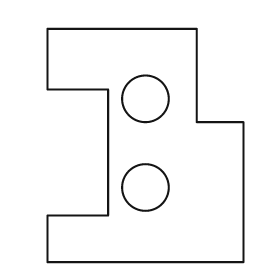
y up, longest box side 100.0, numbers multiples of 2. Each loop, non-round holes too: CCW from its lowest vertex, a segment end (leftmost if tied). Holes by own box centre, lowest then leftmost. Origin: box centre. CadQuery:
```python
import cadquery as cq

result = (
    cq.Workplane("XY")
    .moveTo(-42.0, -50.0)
    .lineTo(42.0, -50.0)
    .lineTo(42.0, 10.0)
    .lineTo(22.0, 10.0)
    .lineTo(22.0, 50.0)
    .lineTo(-42.0, 50.0)
    .lineTo(-42.0, 24.0)
    .lineTo(-16.0, 24.0)
    .lineTo(-16.0, -30.0)
    .lineTo(-42.0, -30.0)
    .close()
    .moveTo(0.0, -18.0)
    .circle(10.0)
    .moveTo(0.0, 20.0)
    .circle(10.0)
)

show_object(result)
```